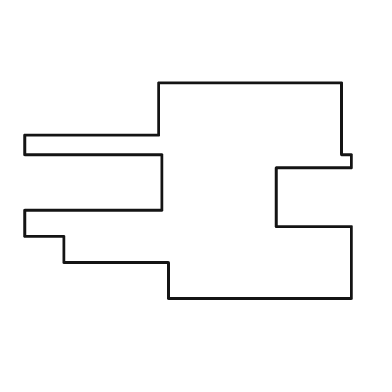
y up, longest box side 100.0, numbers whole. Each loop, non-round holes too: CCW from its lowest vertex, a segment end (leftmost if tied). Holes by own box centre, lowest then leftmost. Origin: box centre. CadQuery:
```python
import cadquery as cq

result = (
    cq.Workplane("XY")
    .moveTo(-6.0, -33.0)
    .lineTo(50.0, -33.0)
    .lineTo(50.0, -11.0)
    .lineTo(27.0, -11.0)
    .lineTo(27.0, 7.0)
    .lineTo(50.0, 7.0)
    .lineTo(50.0, 11.0)
    .lineTo(47.0, 11.0)
    .lineTo(47.0, 33.0)
    .lineTo(-9.0, 33.0)
    .lineTo(-9.0, 17.0)
    .lineTo(-50.0, 17.0)
    .lineTo(-50.0, 11.0)
    .lineTo(-8.0, 11.0)
    .lineTo(-8.0, -6.0)
    .lineTo(-50.0, -6.0)
    .lineTo(-50.0, -14.0)
    .lineTo(-38.0, -14.0)
    .lineTo(-38.0, -22.0)
    .lineTo(-6.0, -22.0)
    .close()
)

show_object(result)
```